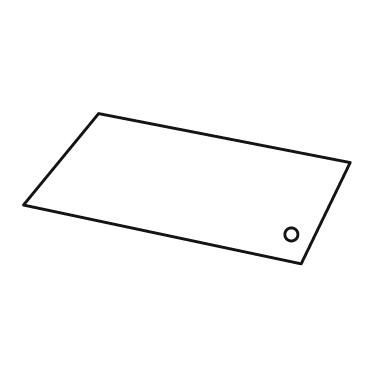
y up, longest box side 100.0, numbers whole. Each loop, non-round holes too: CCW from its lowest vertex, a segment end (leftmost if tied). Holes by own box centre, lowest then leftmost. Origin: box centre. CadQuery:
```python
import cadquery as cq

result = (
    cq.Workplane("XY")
    .moveTo(35.0, -23.0)
    .lineTo(50.0, 8.0)
    .lineTo(-27.0, 23.0)
    .lineTo(-50.0, -5.0)
    .close()
    .moveTo(32.0, -14.0)
    .circle(2.0)
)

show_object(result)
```